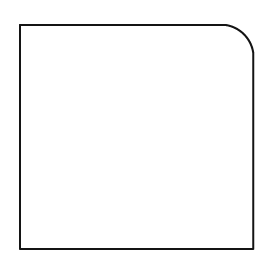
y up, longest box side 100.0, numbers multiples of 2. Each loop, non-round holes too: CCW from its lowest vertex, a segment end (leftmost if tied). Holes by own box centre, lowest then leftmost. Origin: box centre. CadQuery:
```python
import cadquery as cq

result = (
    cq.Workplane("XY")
    .moveTo(-50.0, -48.0)
    .lineTo(50.0, -48.0)
    .lineTo(50.0, 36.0)
    .threePointArc((46.0, 44.0), (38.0, 48.0))
    .lineTo(-50.0, 48.0)
    .close()
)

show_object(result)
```